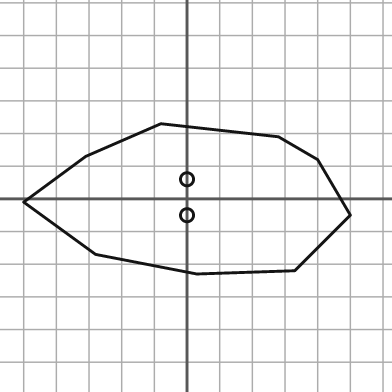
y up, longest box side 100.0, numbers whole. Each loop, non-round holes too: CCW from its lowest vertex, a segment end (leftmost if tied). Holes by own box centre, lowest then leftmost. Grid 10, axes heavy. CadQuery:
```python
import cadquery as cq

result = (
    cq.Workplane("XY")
    .moveTo(3.0, -23.0)
    .lineTo(33.0, -22.0)
    .lineTo(50.0, -5.0)
    .lineTo(40.0, 12.0)
    .lineTo(28.0, 19.0)
    .lineTo(-8.0, 23.0)
    .lineTo(-31.0, 13.0)
    .lineTo(-50.0, -1.0)
    .lineTo(-28.0, -17.0)
    .close()
    .moveTo(0.0, -5.0)
    .circle(2.0)
    .moveTo(0.0, 6.0)
    .circle(2.0)
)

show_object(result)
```